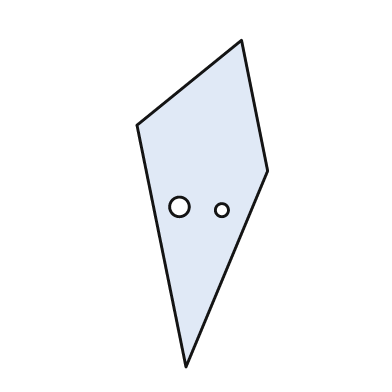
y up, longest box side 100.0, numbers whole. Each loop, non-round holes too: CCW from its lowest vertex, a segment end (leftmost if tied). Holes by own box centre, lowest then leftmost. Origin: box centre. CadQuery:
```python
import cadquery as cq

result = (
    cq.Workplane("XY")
    .moveTo(-5.0, -50.0)
    .lineTo(20.0, 10.0)
    .lineTo(12.0, 50.0)
    .lineTo(-20.0, 24.0)
    .close()
    .moveTo(6.0, -2.0)
    .circle(2.0)
    .moveTo(-7.0, -1.0)
    .circle(3.0)
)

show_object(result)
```